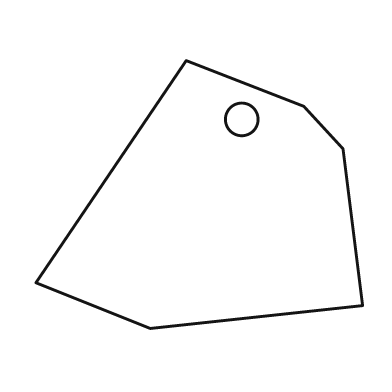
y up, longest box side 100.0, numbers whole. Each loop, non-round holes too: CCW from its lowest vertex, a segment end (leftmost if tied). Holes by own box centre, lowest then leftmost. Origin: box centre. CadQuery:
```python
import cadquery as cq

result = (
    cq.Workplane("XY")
    .moveTo(-15.0, -41.0)
    .lineTo(50.0, -34.0)
    .lineTo(44.0, 14.0)
    .lineTo(32.0, 27.0)
    .lineTo(-4.0, 41.0)
    .lineTo(-50.0, -27.0)
    .close()
    .moveTo(13.0, 23.0)
    .circle(5.0)
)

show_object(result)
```